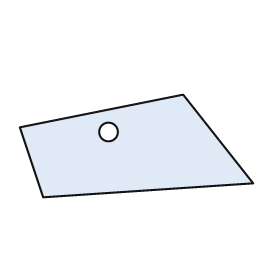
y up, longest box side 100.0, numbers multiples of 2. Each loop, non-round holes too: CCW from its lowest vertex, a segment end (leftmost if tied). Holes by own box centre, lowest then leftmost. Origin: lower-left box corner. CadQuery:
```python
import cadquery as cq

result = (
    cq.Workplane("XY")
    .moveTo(10.0, 0.0)
    .lineTo(100.0, 6.0)
    .lineTo(70.0, 44.0)
    .lineTo(0.0, 30.0)
    .close()
    .moveTo(38.0, 28.0)
    .circle(4.0)
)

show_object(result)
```